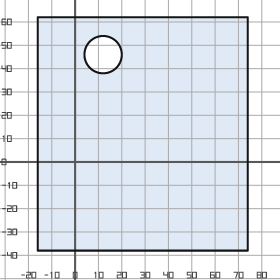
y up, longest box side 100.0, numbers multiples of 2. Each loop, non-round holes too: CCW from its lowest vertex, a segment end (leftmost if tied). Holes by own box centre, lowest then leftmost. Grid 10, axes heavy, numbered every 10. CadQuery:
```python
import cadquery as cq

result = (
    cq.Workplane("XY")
    .moveTo(-16.0, -38.0)
    .lineTo(74.0, -38.0)
    .lineTo(74.0, 62.0)
    .lineTo(-16.0, 62.0)
    .close()
    .moveTo(12.0, 46.0)
    .circle(8.0)
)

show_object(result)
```